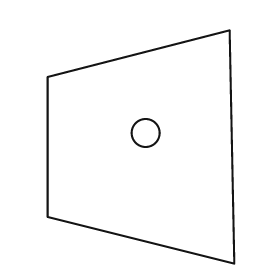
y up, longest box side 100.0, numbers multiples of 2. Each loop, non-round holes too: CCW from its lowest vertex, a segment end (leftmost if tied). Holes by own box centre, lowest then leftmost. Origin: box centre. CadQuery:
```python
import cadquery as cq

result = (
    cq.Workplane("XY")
    .moveTo(40.0, -50.0)
    .lineTo(38.0, 50.0)
    .lineTo(-40.0, 30.0)
    .lineTo(-40.0, -30.0)
    .close()
    .moveTo(2.0, 6.0)
    .circle(6.0)
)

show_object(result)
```